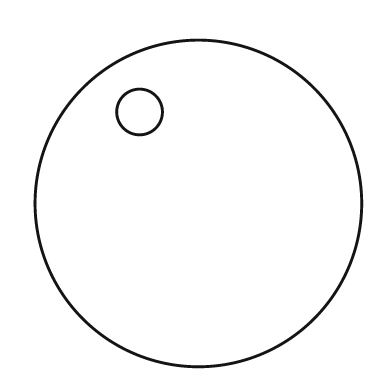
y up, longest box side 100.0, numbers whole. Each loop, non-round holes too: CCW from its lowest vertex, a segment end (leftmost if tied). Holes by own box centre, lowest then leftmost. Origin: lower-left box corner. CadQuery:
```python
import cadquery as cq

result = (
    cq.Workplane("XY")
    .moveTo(50.0, 50.0)
    .circle(50.0)
    .moveTo(32.0, 78.0)
    .circle(7.0)
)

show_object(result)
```